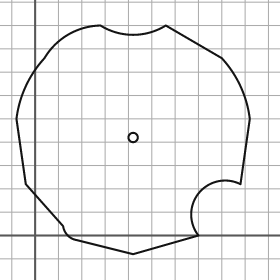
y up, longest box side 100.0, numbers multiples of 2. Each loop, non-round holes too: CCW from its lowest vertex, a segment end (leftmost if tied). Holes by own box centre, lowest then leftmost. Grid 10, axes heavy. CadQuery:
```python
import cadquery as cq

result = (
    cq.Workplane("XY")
    .moveTo(42.0, -8.0)
    .lineTo(70.0, 0.0)
    .threePointArc((70.0, 18.0), (88.0, 22.0))
    .lineTo(92.0, 50.0)
    .threePointArc((88.0, 64.0), (80.0, 76.0))
    .lineTo(56.0, 90.0)
    .threePointArc((42.0, 86.0), (28.0, 90.0))
    .threePointArc((14.0, 86.0), (4.0, 76.0))
    .threePointArc((-4.0, 64.0), (-8.0, 50.0))
    .lineTo(-4.0, 22.0)
    .lineTo(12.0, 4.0)
    .threePointArc((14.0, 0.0), (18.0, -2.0))
    .close()
    .moveTo(42.0, 42.0)
    .circle(2.0)
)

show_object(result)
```